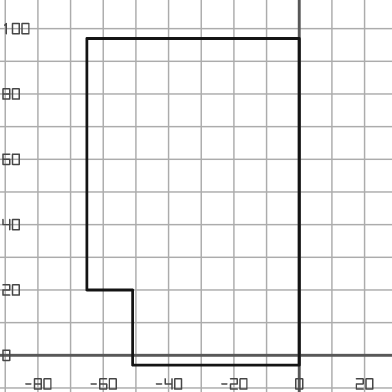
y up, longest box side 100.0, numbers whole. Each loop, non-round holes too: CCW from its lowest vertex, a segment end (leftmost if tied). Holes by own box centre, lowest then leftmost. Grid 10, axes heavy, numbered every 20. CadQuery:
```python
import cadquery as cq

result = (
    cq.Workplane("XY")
    .moveTo(-51.0, -3.0)
    .lineTo(0.0, -3.0)
    .lineTo(0.0, 97.0)
    .lineTo(-65.0, 97.0)
    .lineTo(-65.0, 20.0)
    .lineTo(-51.0, 20.0)
    .close()
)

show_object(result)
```